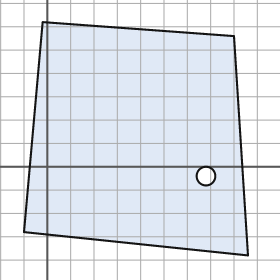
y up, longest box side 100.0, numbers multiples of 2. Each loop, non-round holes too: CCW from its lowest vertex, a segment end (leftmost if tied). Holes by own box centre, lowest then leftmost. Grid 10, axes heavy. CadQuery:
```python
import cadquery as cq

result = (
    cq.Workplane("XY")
    .moveTo(86.0, -38.0)
    .lineTo(80.0, 56.0)
    .lineTo(-2.0, 62.0)
    .lineTo(-10.0, -28.0)
    .close()
    .moveTo(68.0, -4.0)
    .circle(4.0)
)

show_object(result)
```